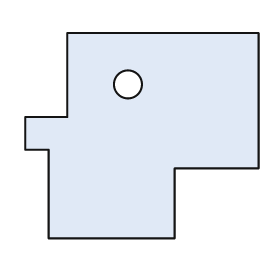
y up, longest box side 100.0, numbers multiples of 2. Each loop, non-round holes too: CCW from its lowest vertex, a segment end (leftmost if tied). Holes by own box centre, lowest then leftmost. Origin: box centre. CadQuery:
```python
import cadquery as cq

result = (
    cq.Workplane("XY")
    .moveTo(-40.0, -44.0)
    .lineTo(14.0, -44.0)
    .lineTo(14.0, -14.0)
    .lineTo(50.0, -14.0)
    .lineTo(50.0, 44.0)
    .lineTo(-32.0, 44.0)
    .lineTo(-32.0, 8.0)
    .lineTo(-50.0, 8.0)
    .lineTo(-50.0, -6.0)
    .lineTo(-40.0, -6.0)
    .close()
    .moveTo(-6.0, 22.0)
    .circle(6.0)
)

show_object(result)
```